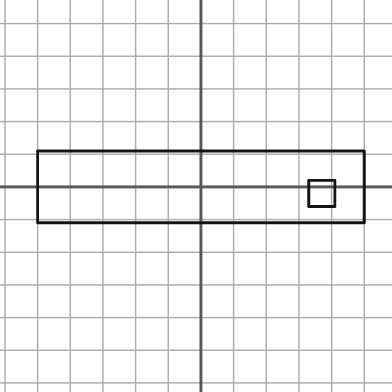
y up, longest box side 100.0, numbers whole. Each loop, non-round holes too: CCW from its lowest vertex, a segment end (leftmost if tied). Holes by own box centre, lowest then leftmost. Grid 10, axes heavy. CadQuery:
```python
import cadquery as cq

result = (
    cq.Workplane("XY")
    .moveTo(-50.0, -11.0)
    .lineTo(50.0, -11.0)
    .lineTo(50.0, 11.0)
    .lineTo(-50.0, 11.0)
    .close()
    .moveTo(33.0, -6.0)
    .lineTo(41.0, -6.0)
    .lineTo(41.0, 2.0)
    .lineTo(33.0, 2.0)
    .close()
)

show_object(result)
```